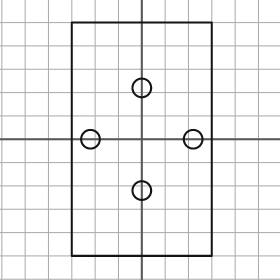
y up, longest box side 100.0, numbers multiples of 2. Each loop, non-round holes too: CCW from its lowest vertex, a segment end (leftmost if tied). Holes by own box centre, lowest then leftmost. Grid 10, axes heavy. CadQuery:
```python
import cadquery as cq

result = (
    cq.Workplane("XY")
    .moveTo(-30.0, -50.0)
    .lineTo(30.0, -50.0)
    .lineTo(30.0, 50.0)
    .lineTo(-30.0, 50.0)
    .close()
    .moveTo(0.0, -22.0)
    .circle(4.0)
    .moveTo(-22.0, 0.0)
    .circle(4.0)
    .moveTo(22.0, 0.0)
    .circle(4.0)
    .moveTo(0.0, 22.0)
    .circle(4.0)
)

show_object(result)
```